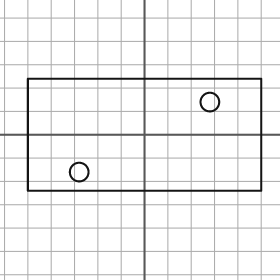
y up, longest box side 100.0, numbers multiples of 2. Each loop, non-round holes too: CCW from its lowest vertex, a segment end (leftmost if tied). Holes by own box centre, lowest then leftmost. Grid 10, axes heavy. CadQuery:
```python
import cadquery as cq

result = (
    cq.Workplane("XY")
    .moveTo(-50.0, -24.0)
    .lineTo(50.0, -24.0)
    .lineTo(50.0, 24.0)
    .lineTo(-50.0, 24.0)
    .close()
    .moveTo(-28.0, -16.0)
    .circle(4.0)
    .moveTo(28.0, 14.0)
    .circle(4.0)
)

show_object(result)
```